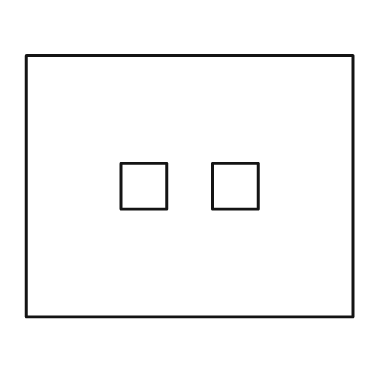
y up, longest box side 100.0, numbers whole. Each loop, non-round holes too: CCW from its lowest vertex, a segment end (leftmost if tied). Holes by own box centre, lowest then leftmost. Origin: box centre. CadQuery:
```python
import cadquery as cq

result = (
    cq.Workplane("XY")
    .moveTo(-50.0, -40.0)
    .lineTo(50.0, -40.0)
    .lineTo(50.0, 40.0)
    .lineTo(-50.0, 40.0)
    .close()
    .moveTo(-21.0, -7.0)
    .lineTo(-7.0, -7.0)
    .lineTo(-7.0, 7.0)
    .lineTo(-21.0, 7.0)
    .close()
    .moveTo(7.0, -7.0)
    .lineTo(21.0, -7.0)
    .lineTo(21.0, 7.0)
    .lineTo(7.0, 7.0)
    .close()
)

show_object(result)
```